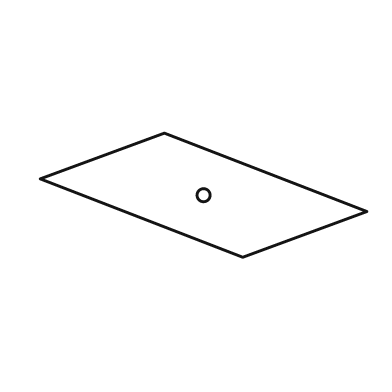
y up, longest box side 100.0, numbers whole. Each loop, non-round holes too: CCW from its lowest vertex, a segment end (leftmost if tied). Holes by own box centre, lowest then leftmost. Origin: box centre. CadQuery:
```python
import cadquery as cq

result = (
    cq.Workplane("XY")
    .moveTo(12.0, -19.0)
    .lineTo(50.0, -5.0)
    .lineTo(-12.0, 19.0)
    .lineTo(-50.0, 5.0)
    .close()
    .moveTo(0.0, 0.0)
    .circle(2.0)
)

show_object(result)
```